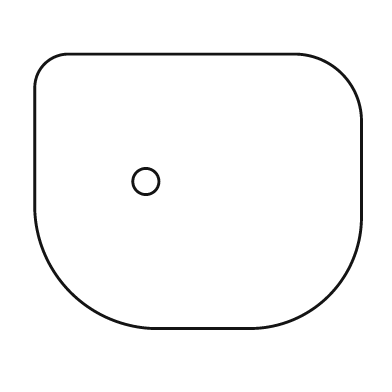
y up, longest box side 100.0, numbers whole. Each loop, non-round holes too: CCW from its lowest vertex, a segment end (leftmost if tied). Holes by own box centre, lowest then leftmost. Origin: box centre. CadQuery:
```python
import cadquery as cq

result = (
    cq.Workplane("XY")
    .moveTo(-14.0, -42.0)
    .lineTo(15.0, -42.0)
    .threePointArc((40.0, -32.0), (50.0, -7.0))
    .lineTo(50.0, 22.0)
    .threePointArc((44.0, 36.0), (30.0, 42.0))
    .lineTo(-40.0, 42.0)
    .threePointArc((-47.0, 39.0), (-50.0, 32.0))
    .lineTo(-50.0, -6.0)
    .threePointArc((-39.0, -31.0), (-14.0, -42.0))
    .close()
    .moveTo(-16.0, 3.0)
    .circle(4.0)
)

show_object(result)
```